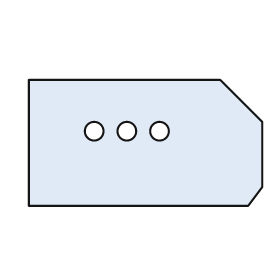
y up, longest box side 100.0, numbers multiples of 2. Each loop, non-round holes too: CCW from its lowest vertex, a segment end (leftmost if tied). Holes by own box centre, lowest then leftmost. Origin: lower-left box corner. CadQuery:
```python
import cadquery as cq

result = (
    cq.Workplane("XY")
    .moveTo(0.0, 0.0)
    .lineTo(94.0, 0.0)
    .lineTo(100.0, 8.0)
    .lineTo(100.0, 36.0)
    .lineTo(82.0, 54.0)
    .lineTo(0.0, 54.0)
    .close()
    .moveTo(28.0, 32.0)
    .circle(4.0)
    .moveTo(42.0, 32.0)
    .circle(4.0)
    .moveTo(56.0, 32.0)
    .circle(4.0)
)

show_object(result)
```